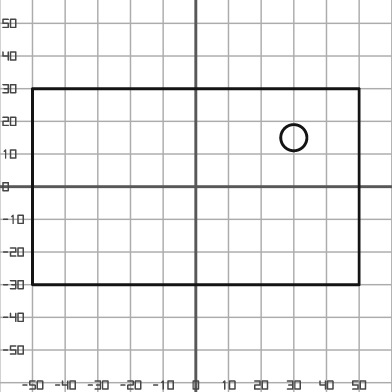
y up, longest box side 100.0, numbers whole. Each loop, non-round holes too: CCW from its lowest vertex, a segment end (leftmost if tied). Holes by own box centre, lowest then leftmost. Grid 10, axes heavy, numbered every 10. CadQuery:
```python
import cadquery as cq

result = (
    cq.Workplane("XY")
    .moveTo(-50.0, -30.0)
    .lineTo(50.0, -30.0)
    .lineTo(50.0, 30.0)
    .lineTo(-50.0, 30.0)
    .close()
    .moveTo(30.0, 15.0)
    .circle(4.0)
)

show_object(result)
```